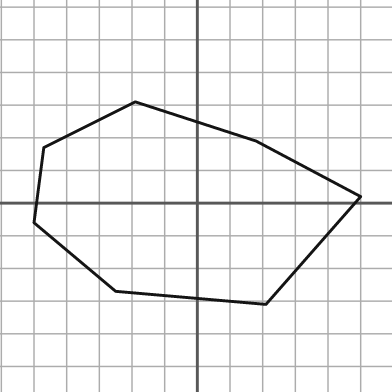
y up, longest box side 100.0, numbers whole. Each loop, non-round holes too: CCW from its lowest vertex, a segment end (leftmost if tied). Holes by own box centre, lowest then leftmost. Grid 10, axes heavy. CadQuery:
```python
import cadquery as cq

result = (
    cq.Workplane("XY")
    .moveTo(21.0, -31.0)
    .lineTo(50.0, 2.0)
    .lineTo(18.0, 19.0)
    .lineTo(-19.0, 31.0)
    .lineTo(-47.0, 17.0)
    .lineTo(-50.0, -6.0)
    .lineTo(-25.0, -27.0)
    .close()
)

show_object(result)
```